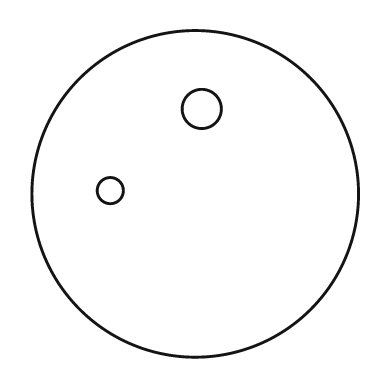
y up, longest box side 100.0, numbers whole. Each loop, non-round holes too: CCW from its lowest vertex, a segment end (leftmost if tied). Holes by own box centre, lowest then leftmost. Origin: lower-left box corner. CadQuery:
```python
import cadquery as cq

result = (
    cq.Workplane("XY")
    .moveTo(50.0, 50.0)
    .circle(50.0)
    .moveTo(24.0, 51.0)
    .circle(4.0)
    .moveTo(52.0, 76.0)
    .circle(6.0)
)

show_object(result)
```